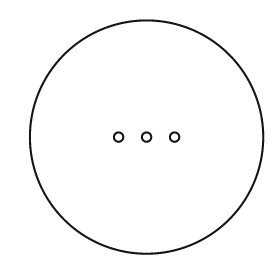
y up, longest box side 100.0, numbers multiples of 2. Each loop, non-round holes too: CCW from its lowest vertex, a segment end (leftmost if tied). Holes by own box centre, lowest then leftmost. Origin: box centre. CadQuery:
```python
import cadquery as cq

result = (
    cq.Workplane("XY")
    .moveTo(0.0, 0.0)
    .circle(50.0)
    .moveTo(-12.0, 0.0)
    .circle(2.0)
    .moveTo(0.0, 0.0)
    .circle(2.0)
    .moveTo(12.0, 0.0)
    .circle(2.0)
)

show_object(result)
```